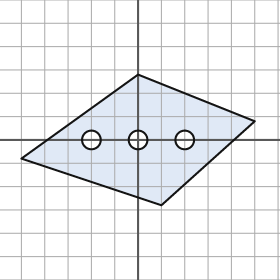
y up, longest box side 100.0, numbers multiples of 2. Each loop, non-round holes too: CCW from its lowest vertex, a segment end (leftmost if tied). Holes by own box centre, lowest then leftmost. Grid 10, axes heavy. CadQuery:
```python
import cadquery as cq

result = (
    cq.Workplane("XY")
    .moveTo(10.0, -28.0)
    .lineTo(50.0, 8.0)
    .lineTo(0.0, 28.0)
    .lineTo(-50.0, -8.0)
    .close()
    .moveTo(-20.0, 0.0)
    .circle(4.0)
    .moveTo(0.0, 0.0)
    .circle(4.0)
    .moveTo(20.0, 0.0)
    .circle(4.0)
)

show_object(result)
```